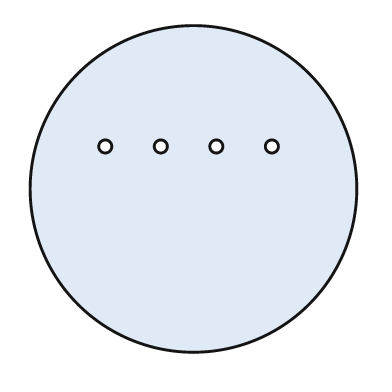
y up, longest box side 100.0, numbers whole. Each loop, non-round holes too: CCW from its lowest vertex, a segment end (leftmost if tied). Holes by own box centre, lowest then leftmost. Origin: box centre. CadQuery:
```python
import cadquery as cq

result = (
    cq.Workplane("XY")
    .moveTo(0.0, 0.0)
    .circle(50.0)
    .moveTo(-27.0, 13.0)
    .circle(2.0)
    .moveTo(-10.0, 13.0)
    .circle(2.0)
    .moveTo(7.0, 13.0)
    .circle(2.0)
    .moveTo(24.0, 13.0)
    .circle(2.0)
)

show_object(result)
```